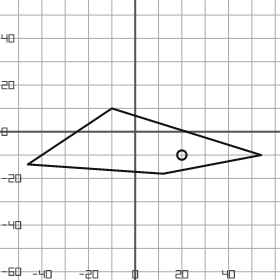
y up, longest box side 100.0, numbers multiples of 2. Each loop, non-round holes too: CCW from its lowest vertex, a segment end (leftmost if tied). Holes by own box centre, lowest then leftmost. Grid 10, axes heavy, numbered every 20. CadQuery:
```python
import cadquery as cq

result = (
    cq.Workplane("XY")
    .moveTo(12.0, -18.0)
    .lineTo(54.0, -10.0)
    .lineTo(-10.0, 10.0)
    .lineTo(-46.0, -14.0)
    .close()
    .moveTo(20.0, -10.0)
    .circle(2.0)
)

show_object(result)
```